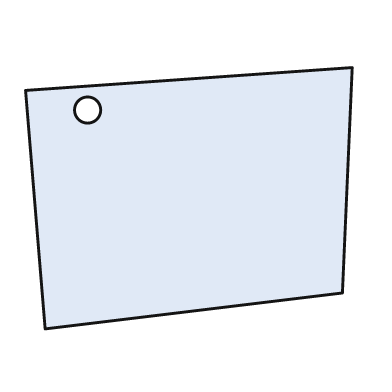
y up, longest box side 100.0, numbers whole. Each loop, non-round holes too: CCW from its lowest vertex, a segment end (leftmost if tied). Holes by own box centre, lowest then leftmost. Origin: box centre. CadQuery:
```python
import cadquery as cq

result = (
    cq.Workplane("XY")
    .moveTo(-44.0, -40.0)
    .lineTo(47.0, -29.0)
    .lineTo(50.0, 40.0)
    .lineTo(-50.0, 33.0)
    .close()
    .moveTo(-31.0, 27.0)
    .circle(4.0)
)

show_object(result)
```